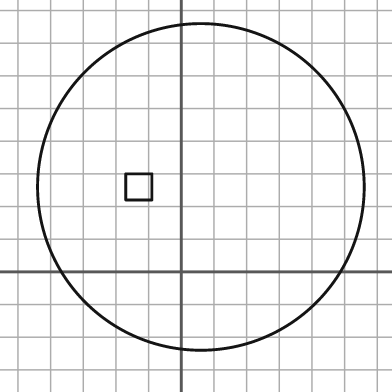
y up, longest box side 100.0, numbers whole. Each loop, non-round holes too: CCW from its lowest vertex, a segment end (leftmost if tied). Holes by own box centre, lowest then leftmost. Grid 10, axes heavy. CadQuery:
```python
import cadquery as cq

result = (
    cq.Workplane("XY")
    .moveTo(6.0, 26.0)
    .circle(50.0)
    .moveTo(-17.0, 22.0)
    .lineTo(-9.0, 22.0)
    .lineTo(-9.0, 30.0)
    .lineTo(-17.0, 30.0)
    .close()
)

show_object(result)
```